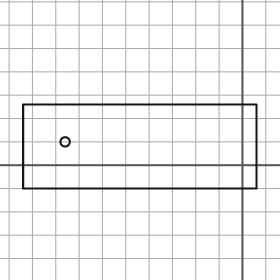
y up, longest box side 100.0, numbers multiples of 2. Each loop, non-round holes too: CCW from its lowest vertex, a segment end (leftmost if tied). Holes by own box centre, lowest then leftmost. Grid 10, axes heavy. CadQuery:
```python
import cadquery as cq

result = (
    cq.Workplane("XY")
    .moveTo(-94.0, -10.0)
    .lineTo(6.0, -10.0)
    .lineTo(6.0, 26.0)
    .lineTo(-94.0, 26.0)
    .close()
    .moveTo(-76.0, 10.0)
    .circle(2.0)
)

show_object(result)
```